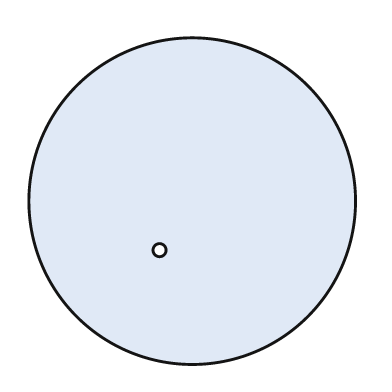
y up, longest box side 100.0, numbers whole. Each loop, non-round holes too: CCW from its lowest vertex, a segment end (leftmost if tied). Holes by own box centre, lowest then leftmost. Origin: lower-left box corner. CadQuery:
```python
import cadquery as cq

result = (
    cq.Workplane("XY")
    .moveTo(50.0, 50.0)
    .circle(50.0)
    .moveTo(40.0, 35.0)
    .circle(2.0)
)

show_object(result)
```